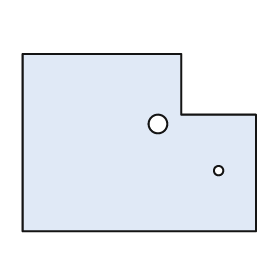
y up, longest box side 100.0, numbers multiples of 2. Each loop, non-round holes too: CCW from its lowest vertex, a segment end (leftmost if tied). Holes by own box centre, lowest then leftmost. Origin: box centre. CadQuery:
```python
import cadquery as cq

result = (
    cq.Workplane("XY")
    .moveTo(-50.0, -38.0)
    .lineTo(50.0, -38.0)
    .lineTo(50.0, 12.0)
    .lineTo(18.0, 12.0)
    .lineTo(18.0, 38.0)
    .lineTo(-50.0, 38.0)
    .close()
    .moveTo(34.0, -12.0)
    .circle(2.0)
    .moveTo(8.0, 8.0)
    .circle(4.0)
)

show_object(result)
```